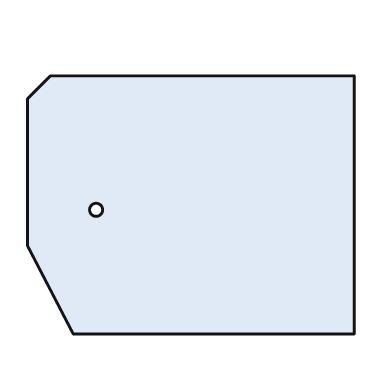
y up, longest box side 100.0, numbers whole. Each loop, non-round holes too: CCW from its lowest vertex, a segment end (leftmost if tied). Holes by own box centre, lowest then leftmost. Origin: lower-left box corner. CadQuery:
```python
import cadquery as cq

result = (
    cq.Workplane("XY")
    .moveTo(14.0, 0.0)
    .lineTo(100.0, 0.0)
    .lineTo(100.0, 79.0)
    .lineTo(7.0, 79.0)
    .lineTo(0.0, 72.0)
    .lineTo(0.0, 27.0)
    .close()
    .moveTo(21.0, 38.0)
    .circle(2.0)
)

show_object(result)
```